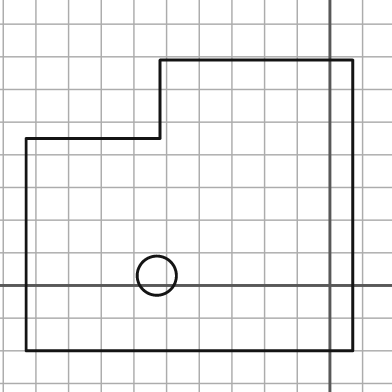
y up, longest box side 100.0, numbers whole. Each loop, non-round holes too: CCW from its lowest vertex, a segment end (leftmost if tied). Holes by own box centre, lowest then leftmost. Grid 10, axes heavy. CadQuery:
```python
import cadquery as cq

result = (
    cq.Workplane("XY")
    .moveTo(-93.0, -20.0)
    .lineTo(7.0, -20.0)
    .lineTo(7.0, 69.0)
    .lineTo(-52.0, 69.0)
    .lineTo(-52.0, 45.0)
    .lineTo(-93.0, 45.0)
    .close()
    .moveTo(-53.0, 3.0)
    .circle(6.0)
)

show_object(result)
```